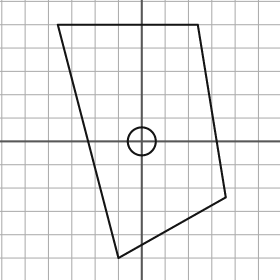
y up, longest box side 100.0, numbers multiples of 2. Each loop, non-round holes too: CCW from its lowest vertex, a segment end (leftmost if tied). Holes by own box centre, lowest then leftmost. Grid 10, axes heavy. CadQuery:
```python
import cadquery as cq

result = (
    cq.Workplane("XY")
    .moveTo(-10.0, -50.0)
    .lineTo(36.0, -24.0)
    .lineTo(24.0, 50.0)
    .lineTo(-36.0, 50.0)
    .close()
    .moveTo(0.0, 0.0)
    .circle(6.0)
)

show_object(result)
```